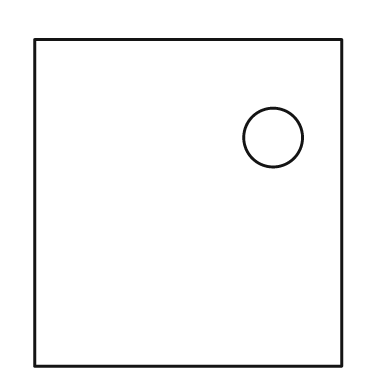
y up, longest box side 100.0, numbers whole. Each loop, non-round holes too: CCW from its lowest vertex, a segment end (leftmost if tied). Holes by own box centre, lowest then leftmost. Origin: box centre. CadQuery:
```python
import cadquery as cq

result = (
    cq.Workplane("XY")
    .moveTo(-47.0, -50.0)
    .lineTo(47.0, -50.0)
    .lineTo(47.0, 50.0)
    .lineTo(-47.0, 50.0)
    .close()
    .moveTo(26.0, 20.0)
    .circle(9.0)
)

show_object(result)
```